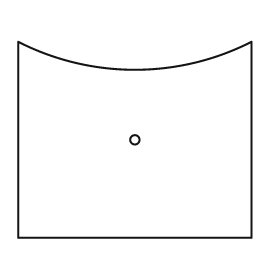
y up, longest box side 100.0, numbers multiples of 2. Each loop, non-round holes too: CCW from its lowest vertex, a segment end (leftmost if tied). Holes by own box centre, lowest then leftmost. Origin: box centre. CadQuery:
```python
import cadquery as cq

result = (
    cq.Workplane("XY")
    .moveTo(-50.0, -42.0)
    .lineTo(50.0, -42.0)
    .lineTo(50.0, 42.0)
    .threePointArc((0.0, 30.0), (-50.0, 42.0))
    .close()
    .moveTo(0.0, 0.0)
    .circle(2.0)
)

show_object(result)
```